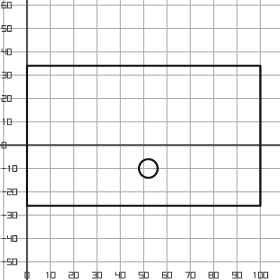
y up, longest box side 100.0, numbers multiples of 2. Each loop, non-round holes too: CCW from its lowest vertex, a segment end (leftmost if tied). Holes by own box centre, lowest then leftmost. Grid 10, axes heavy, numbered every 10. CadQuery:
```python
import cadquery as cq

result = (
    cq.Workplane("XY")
    .moveTo(0.0, -26.0)
    .lineTo(100.0, -26.0)
    .lineTo(100.0, 34.0)
    .lineTo(0.0, 34.0)
    .close()
    .moveTo(52.0, -10.0)
    .circle(4.0)
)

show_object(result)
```